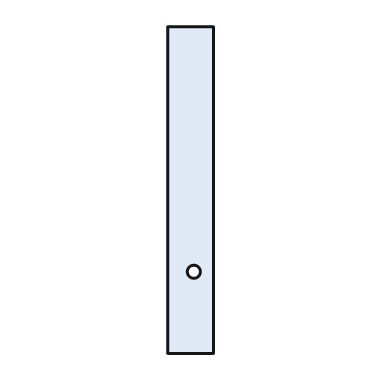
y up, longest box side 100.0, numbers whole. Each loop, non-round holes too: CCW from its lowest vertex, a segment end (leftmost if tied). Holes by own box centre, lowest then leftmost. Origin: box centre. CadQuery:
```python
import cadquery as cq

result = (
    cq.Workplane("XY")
    .moveTo(-7.0, -50.0)
    .lineTo(7.0, -50.0)
    .lineTo(7.0, 50.0)
    .lineTo(-7.0, 50.0)
    .close()
    .moveTo(1.0, -25.0)
    .circle(2.0)
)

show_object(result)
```